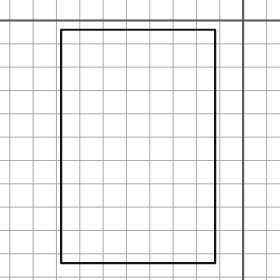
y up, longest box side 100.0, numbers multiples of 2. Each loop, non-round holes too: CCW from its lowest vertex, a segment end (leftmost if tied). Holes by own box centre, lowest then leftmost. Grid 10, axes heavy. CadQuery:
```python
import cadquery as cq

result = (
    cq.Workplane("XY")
    .moveTo(-78.0, -104.0)
    .lineTo(-12.0, -104.0)
    .lineTo(-12.0, -4.0)
    .lineTo(-78.0, -4.0)
    .close()
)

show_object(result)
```